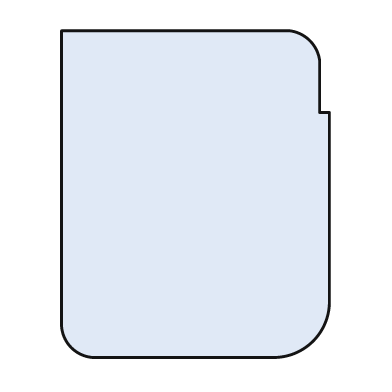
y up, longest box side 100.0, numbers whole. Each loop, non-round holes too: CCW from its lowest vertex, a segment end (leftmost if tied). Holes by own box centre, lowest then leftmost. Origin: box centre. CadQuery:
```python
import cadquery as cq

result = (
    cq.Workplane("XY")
    .moveTo(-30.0, -50.0)
    .lineTo(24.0, -50.0)
    .threePointArc((36.0, -45.0), (41.0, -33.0))
    .lineTo(41.0, 25.0)
    .lineTo(38.0, 25.0)
    .lineTo(38.0, 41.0)
    .threePointArc((35.0, 47.0), (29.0, 50.0))
    .lineTo(-41.0, 50.0)
    .lineTo(-41.0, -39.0)
    .threePointArc((-38.0, -47.0), (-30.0, -50.0))
    .close()
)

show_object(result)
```